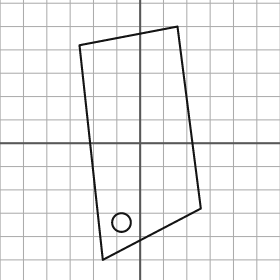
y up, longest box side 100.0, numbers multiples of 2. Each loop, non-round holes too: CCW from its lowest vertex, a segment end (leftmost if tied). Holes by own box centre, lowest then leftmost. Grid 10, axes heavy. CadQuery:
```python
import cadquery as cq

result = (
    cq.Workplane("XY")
    .moveTo(-16.0, -50.0)
    .lineTo(26.0, -28.0)
    .lineTo(16.0, 50.0)
    .lineTo(-26.0, 42.0)
    .close()
    .moveTo(-8.0, -34.0)
    .circle(4.0)
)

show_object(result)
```